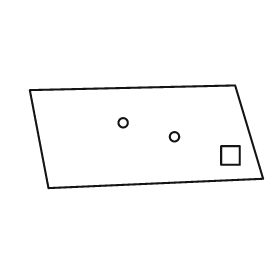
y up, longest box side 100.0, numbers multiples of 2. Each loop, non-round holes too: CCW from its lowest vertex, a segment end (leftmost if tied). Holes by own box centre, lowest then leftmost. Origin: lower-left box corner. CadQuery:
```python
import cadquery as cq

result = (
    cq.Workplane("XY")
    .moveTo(8.0, 0.0)
    .lineTo(100.0, 4.0)
    .lineTo(88.0, 44.0)
    .lineTo(0.0, 42.0)
    .close()
    .moveTo(82.0, 10.0)
    .lineTo(90.0, 10.0)
    .lineTo(90.0, 18.0)
    .lineTo(82.0, 18.0)
    .close()
    .moveTo(62.0, 22.0)
    .circle(2.0)
    .moveTo(40.0, 28.0)
    .circle(2.0)
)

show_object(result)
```